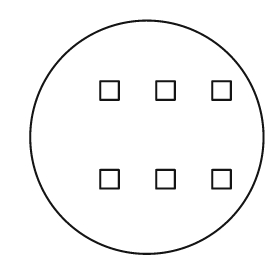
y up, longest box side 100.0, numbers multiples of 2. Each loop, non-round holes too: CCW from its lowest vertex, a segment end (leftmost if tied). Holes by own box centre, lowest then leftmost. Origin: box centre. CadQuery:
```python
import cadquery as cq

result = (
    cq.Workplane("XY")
    .moveTo(0.0, 0.0)
    .circle(50.0)
    .moveTo(-20.0, -22.0)
    .lineTo(-12.0, -22.0)
    .lineTo(-12.0, -14.0)
    .lineTo(-20.0, -14.0)
    .close()
    .moveTo(4.0, -22.0)
    .lineTo(12.0, -22.0)
    .lineTo(12.0, -14.0)
    .lineTo(4.0, -14.0)
    .close()
    .moveTo(28.0, -22.0)
    .lineTo(36.0, -22.0)
    .lineTo(36.0, -14.0)
    .lineTo(28.0, -14.0)
    .close()
    .moveTo(-20.0, 16.0)
    .lineTo(-12.0, 16.0)
    .lineTo(-12.0, 24.0)
    .lineTo(-20.0, 24.0)
    .close()
    .moveTo(4.0, 16.0)
    .lineTo(12.0, 16.0)
    .lineTo(12.0, 24.0)
    .lineTo(4.0, 24.0)
    .close()
    .moveTo(28.0, 16.0)
    .lineTo(36.0, 16.0)
    .lineTo(36.0, 24.0)
    .lineTo(28.0, 24.0)
    .close()
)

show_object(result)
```